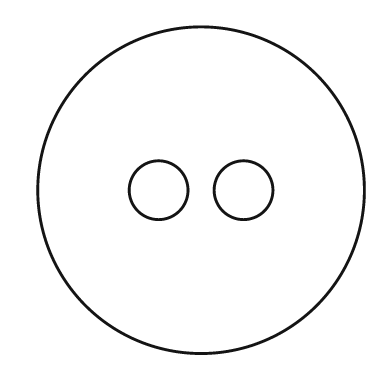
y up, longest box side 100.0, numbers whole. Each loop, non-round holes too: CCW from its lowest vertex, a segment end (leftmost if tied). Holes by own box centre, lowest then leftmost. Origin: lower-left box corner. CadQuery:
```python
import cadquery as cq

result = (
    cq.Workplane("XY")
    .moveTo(50.0, 50.0)
    .circle(50.0)
    .moveTo(37.0, 50.0)
    .circle(9.0)
    .moveTo(63.0, 50.0)
    .circle(9.0)
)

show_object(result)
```